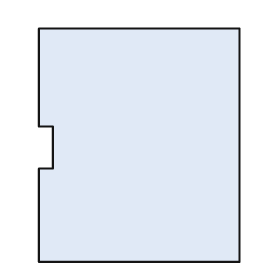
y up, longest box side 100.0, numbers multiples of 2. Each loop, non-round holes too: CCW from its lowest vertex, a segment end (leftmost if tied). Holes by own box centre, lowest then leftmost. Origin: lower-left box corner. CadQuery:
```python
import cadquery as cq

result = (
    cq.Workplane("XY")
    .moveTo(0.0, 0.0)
    .lineTo(86.0, 0.0)
    .lineTo(86.0, 100.0)
    .lineTo(0.0, 100.0)
    .lineTo(0.0, 58.0)
    .lineTo(6.0, 58.0)
    .lineTo(6.0, 40.0)
    .lineTo(0.0, 40.0)
    .close()
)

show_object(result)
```